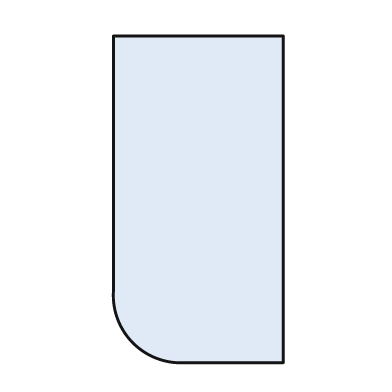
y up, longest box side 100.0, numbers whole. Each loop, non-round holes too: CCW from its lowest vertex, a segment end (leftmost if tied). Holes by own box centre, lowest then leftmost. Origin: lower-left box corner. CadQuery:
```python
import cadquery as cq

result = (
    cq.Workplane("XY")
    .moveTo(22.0, 0.0)
    .lineTo(52.0, 0.0)
    .lineTo(52.0, 100.0)
    .lineTo(0.0, 100.0)
    .lineTo(0.0, 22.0)
    .threePointArc((6.0, 6.0), (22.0, 0.0))
    .close()
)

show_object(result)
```